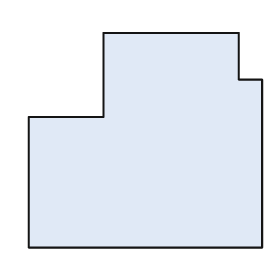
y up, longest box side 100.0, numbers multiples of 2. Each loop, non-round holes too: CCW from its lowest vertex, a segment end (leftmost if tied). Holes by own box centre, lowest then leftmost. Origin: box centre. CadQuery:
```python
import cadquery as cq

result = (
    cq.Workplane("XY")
    .moveTo(-50.0, -46.0)
    .lineTo(50.0, -46.0)
    .lineTo(50.0, 26.0)
    .lineTo(40.0, 26.0)
    .lineTo(40.0, 46.0)
    .lineTo(-18.0, 46.0)
    .lineTo(-18.0, 10.0)
    .lineTo(-50.0, 10.0)
    .close()
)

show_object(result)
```